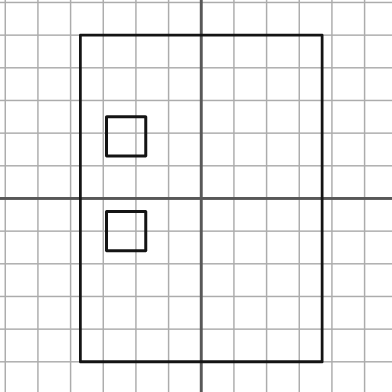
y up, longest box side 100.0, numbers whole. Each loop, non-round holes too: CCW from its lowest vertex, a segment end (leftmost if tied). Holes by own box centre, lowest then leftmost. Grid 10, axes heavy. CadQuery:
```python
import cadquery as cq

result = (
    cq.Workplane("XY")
    .moveTo(-37.0, -50.0)
    .lineTo(37.0, -50.0)
    .lineTo(37.0, 50.0)
    .lineTo(-37.0, 50.0)
    .close()
    .moveTo(-29.0, -16.0)
    .lineTo(-17.0, -16.0)
    .lineTo(-17.0, -4.0)
    .lineTo(-29.0, -4.0)
    .close()
    .moveTo(-29.0, 13.0)
    .lineTo(-17.0, 13.0)
    .lineTo(-17.0, 25.0)
    .lineTo(-29.0, 25.0)
    .close()
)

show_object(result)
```